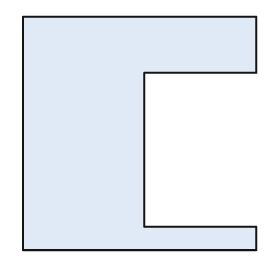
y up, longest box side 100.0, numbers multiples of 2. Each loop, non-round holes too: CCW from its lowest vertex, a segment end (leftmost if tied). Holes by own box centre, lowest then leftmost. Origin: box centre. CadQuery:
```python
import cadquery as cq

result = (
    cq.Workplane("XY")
    .moveTo(-50.0, -50.0)
    .lineTo(50.0, -50.0)
    .lineTo(50.0, -40.0)
    .lineTo(2.0, -40.0)
    .lineTo(2.0, 26.0)
    .lineTo(50.0, 26.0)
    .lineTo(50.0, 50.0)
    .lineTo(-50.0, 50.0)
    .close()
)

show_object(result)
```